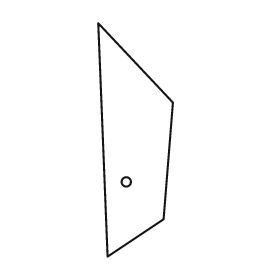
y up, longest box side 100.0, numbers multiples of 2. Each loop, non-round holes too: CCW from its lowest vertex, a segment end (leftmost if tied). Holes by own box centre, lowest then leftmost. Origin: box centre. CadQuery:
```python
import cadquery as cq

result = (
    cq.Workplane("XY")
    .moveTo(-12.0, -50.0)
    .lineTo(12.0, -34.0)
    .lineTo(16.0, 16.0)
    .lineTo(-16.0, 50.0)
    .close()
    .moveTo(-4.0, -18.0)
    .circle(2.0)
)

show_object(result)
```